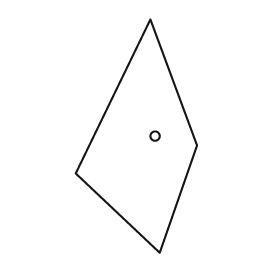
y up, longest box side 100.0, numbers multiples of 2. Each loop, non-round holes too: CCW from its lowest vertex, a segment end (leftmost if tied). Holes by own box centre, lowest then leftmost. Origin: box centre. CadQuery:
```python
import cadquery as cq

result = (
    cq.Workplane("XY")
    .moveTo(10.0, -50.0)
    .lineTo(26.0, -4.0)
    .lineTo(6.0, 50.0)
    .lineTo(-26.0, -16.0)
    .close()
    .moveTo(8.0, 0.0)
    .circle(2.0)
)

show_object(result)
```